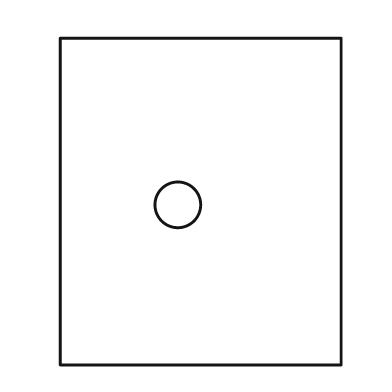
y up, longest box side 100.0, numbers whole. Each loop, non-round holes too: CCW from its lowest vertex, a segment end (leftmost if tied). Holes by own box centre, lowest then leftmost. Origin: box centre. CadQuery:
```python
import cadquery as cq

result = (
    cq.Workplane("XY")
    .moveTo(-43.0, -50.0)
    .lineTo(43.0, -50.0)
    .lineTo(43.0, 50.0)
    .lineTo(-43.0, 50.0)
    .close()
    .moveTo(-7.0, -1.0)
    .circle(7.0)
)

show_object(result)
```